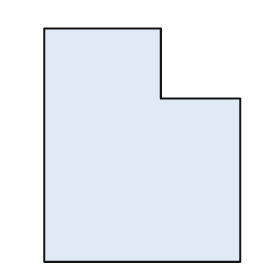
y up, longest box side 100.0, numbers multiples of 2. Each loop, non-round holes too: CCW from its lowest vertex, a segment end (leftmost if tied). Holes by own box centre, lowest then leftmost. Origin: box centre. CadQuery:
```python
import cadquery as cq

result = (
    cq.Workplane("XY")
    .moveTo(-42.0, -50.0)
    .lineTo(42.0, -50.0)
    .lineTo(42.0, 20.0)
    .lineTo(8.0, 20.0)
    .lineTo(8.0, 50.0)
    .lineTo(-42.0, 50.0)
    .close()
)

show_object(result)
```